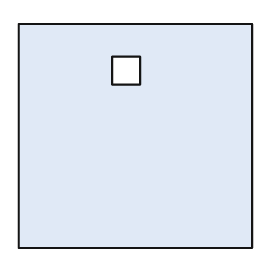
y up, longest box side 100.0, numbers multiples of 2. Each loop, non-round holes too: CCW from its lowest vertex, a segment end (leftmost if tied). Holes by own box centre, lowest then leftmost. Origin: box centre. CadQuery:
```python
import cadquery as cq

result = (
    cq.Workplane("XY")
    .moveTo(-50.0, -48.0)
    .lineTo(50.0, -48.0)
    .lineTo(50.0, 48.0)
    .lineTo(-50.0, 48.0)
    .close()
    .moveTo(-10.0, 22.0)
    .lineTo(2.0, 22.0)
    .lineTo(2.0, 34.0)
    .lineTo(-10.0, 34.0)
    .close()
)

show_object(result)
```